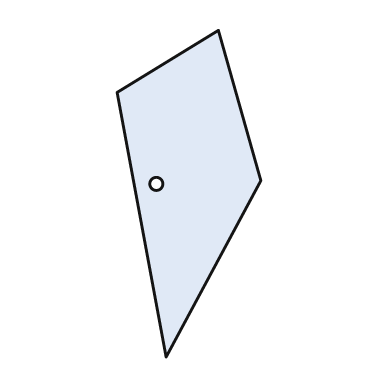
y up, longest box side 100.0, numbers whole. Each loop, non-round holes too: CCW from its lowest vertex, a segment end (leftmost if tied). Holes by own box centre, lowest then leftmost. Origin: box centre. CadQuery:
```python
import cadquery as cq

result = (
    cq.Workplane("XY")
    .moveTo(-7.0, -50.0)
    .lineTo(22.0, 4.0)
    .lineTo(9.0, 50.0)
    .lineTo(-22.0, 31.0)
    .close()
    .moveTo(-10.0, 3.0)
    .circle(2.0)
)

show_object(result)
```